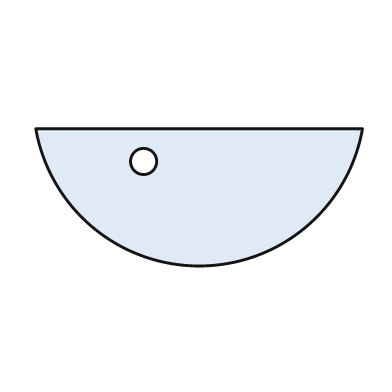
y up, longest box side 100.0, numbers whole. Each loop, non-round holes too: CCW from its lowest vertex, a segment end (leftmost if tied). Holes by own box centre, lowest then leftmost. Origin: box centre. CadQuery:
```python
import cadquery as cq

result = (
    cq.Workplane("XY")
    .moveTo(-50.0, 21.0)
    .threePointArc((0.0, -21.0), (50.0, 21.0))
    .close()
    .moveTo(-17.0, 11.0)
    .circle(4.0)
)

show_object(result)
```